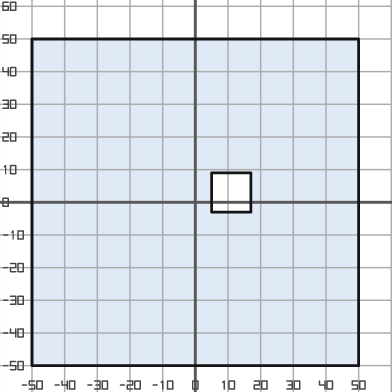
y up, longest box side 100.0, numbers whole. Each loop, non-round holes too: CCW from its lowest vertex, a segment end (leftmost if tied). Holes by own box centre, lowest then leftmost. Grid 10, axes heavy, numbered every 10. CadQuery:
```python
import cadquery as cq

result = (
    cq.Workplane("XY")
    .moveTo(-50.0, -50.0)
    .lineTo(50.0, -50.0)
    .lineTo(50.0, 50.0)
    .lineTo(-50.0, 50.0)
    .close()
    .moveTo(5.0, -3.0)
    .lineTo(17.0, -3.0)
    .lineTo(17.0, 9.0)
    .lineTo(5.0, 9.0)
    .close()
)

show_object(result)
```